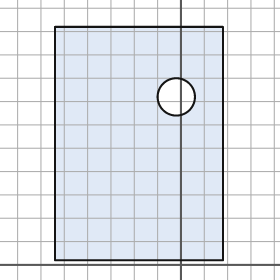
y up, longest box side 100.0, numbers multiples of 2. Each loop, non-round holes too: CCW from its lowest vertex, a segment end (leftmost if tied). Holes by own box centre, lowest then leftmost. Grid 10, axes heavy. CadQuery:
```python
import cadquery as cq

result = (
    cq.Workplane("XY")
    .moveTo(-54.0, 2.0)
    .lineTo(18.0, 2.0)
    .lineTo(18.0, 102.0)
    .lineTo(-54.0, 102.0)
    .close()
    .moveTo(-2.0, 72.0)
    .circle(8.0)
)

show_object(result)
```